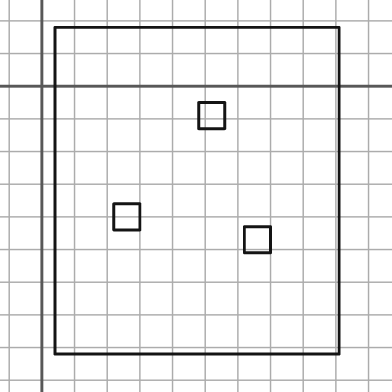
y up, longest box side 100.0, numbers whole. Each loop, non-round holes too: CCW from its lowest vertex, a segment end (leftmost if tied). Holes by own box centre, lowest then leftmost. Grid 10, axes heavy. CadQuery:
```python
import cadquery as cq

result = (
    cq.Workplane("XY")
    .moveTo(4.0, -82.0)
    .lineTo(91.0, -82.0)
    .lineTo(91.0, 18.0)
    .lineTo(4.0, 18.0)
    .close()
    .moveTo(62.0, -51.0)
    .lineTo(70.0, -51.0)
    .lineTo(70.0, -43.0)
    .lineTo(62.0, -43.0)
    .close()
    .moveTo(22.0, -44.0)
    .lineTo(30.0, -44.0)
    .lineTo(30.0, -36.0)
    .lineTo(22.0, -36.0)
    .close()
    .moveTo(48.0, -13.0)
    .lineTo(56.0, -13.0)
    .lineTo(56.0, -5.0)
    .lineTo(48.0, -5.0)
    .close()
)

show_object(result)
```